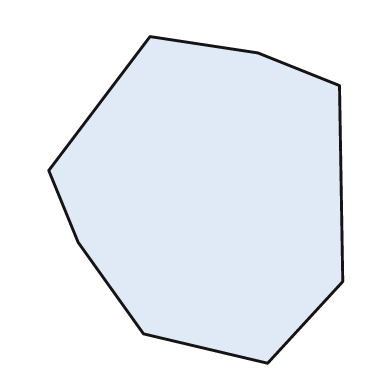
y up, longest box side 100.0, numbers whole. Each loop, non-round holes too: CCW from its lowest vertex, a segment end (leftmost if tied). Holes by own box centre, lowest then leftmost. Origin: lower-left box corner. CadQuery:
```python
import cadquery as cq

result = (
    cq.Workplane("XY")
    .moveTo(67.0, 0.0)
    .lineTo(90.0, 25.0)
    .lineTo(89.0, 85.0)
    .lineTo(64.0, 95.0)
    .lineTo(31.0, 100.0)
    .lineTo(0.0, 59.0)
    .lineTo(9.0, 37.0)
    .lineTo(29.0, 9.0)
    .close()
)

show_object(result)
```